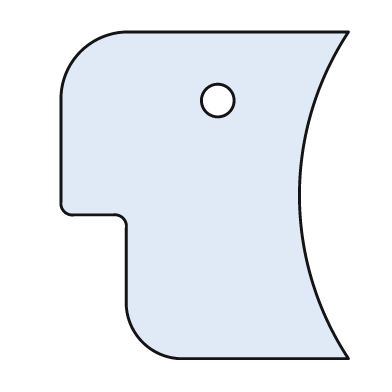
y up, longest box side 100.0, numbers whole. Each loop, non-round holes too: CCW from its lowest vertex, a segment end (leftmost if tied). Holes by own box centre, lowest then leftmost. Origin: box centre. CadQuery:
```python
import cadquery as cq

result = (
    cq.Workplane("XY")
    .moveTo(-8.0, -50.0)
    .lineTo(44.0, -50.0)
    .threePointArc((29.0, 0.0), (44.0, 50.0))
    .lineTo(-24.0, 50.0)
    .threePointArc((-38.0, 44.0), (-44.0, 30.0))
    .lineTo(-44.0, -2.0)
    .threePointArc((-43.0, -5.0), (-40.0, -6.0))
    .lineTo(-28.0, -6.0)
    .threePointArc((-25.0, -7.0), (-24.0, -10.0))
    .lineTo(-24.0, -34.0)
    .threePointArc((-19.0, -45.0), (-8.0, -50.0))
    .close()
    .moveTo(4.0, 29.0)
    .circle(5.0)
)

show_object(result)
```